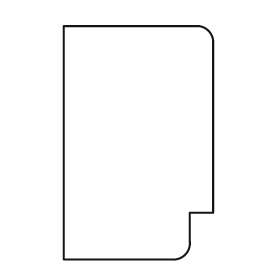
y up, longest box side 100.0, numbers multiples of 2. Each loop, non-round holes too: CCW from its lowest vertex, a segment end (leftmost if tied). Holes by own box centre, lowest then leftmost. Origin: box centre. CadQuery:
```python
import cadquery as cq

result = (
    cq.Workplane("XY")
    .moveTo(-32.0, -50.0)
    .lineTo(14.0, -50.0)
    .threePointArc((20.0, -48.0), (22.0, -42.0))
    .lineTo(22.0, -30.0)
    .lineTo(32.0, -30.0)
    .lineTo(32.0, 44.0)
    .threePointArc((30.0, 48.0), (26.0, 50.0))
    .lineTo(-32.0, 50.0)
    .close()
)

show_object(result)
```